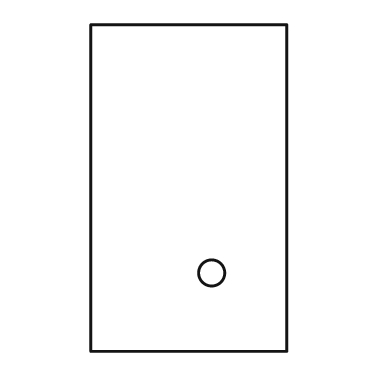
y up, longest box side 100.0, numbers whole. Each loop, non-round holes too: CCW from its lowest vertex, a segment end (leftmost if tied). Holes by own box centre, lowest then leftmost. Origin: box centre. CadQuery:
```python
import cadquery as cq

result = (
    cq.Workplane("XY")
    .moveTo(-30.0, -50.0)
    .lineTo(30.0, -50.0)
    .lineTo(30.0, 50.0)
    .lineTo(-30.0, 50.0)
    .close()
    .moveTo(7.0, -26.0)
    .circle(4.0)
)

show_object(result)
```